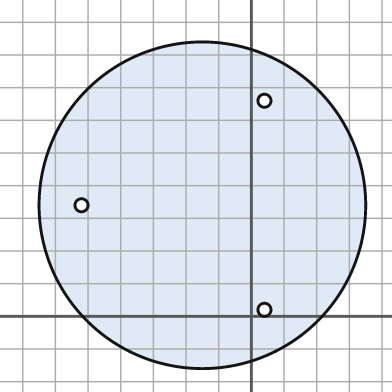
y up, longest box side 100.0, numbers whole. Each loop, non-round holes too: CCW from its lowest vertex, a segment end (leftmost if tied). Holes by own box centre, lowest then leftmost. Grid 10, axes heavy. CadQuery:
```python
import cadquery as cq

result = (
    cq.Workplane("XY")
    .moveTo(-15.0, 34.0)
    .circle(50.0)
    .moveTo(4.0, 2.0)
    .circle(2.0)
    .moveTo(-52.0, 34.0)
    .circle(2.0)
    .moveTo(4.0, 66.0)
    .circle(2.0)
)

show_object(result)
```